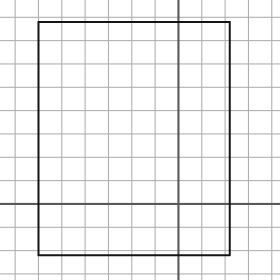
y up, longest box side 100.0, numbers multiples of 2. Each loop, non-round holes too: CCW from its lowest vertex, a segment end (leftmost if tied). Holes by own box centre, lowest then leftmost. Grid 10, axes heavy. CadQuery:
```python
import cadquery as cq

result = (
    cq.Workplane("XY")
    .moveTo(-60.0, -22.0)
    .lineTo(22.0, -22.0)
    .lineTo(22.0, 78.0)
    .lineTo(-60.0, 78.0)
    .close()
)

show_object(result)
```